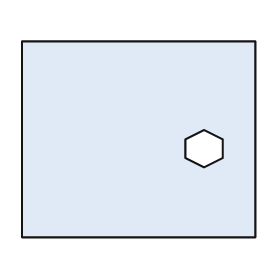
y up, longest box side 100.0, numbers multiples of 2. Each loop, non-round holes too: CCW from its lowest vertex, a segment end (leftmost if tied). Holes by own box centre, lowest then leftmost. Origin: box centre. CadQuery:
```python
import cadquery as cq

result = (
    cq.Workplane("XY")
    .moveTo(-50.0, -42.0)
    .lineTo(50.0, -42.0)
    .lineTo(50.0, 42.0)
    .lineTo(-50.0, 42.0)
    .close()
    .moveTo(28.0, -12.0)
    .lineTo(36.0, -8.0)
    .lineTo(36.0, 0.0)
    .lineTo(28.0, 4.0)
    .lineTo(20.0, 0.0)
    .lineTo(20.0, -8.0)
    .close()
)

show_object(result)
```